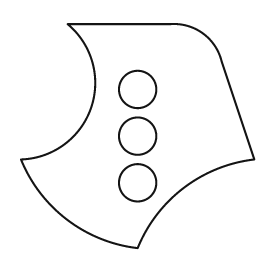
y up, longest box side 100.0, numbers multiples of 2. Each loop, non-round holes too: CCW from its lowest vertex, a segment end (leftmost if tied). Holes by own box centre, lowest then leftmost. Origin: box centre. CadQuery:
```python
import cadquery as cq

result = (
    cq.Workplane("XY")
    .moveTo(0.0, -48.0)
    .threePointArc((20.0, -22.0), (50.0, -10.0))
    .lineTo(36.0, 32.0)
    .threePointArc((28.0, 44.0), (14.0, 48.0))
    .lineTo(-30.0, 48.0)
    .threePointArc((-20.0, 12.0), (-50.0, -10.0))
    .threePointArc((-30.0, -36.0), (0.0, -48.0))
    .close()
    .moveTo(0.0, -20.0)
    .circle(8.0)
    .moveTo(0.0, 0.0)
    .circle(8.0)
    .moveTo(0.0, 20.0)
    .circle(8.0)
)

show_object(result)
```